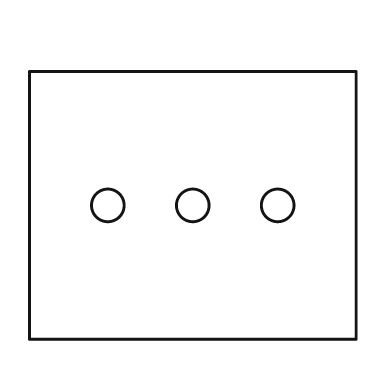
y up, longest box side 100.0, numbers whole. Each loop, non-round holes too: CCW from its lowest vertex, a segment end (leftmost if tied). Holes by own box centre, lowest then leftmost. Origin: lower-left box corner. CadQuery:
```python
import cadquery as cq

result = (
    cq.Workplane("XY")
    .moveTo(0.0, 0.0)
    .lineTo(100.0, 0.0)
    .lineTo(100.0, 82.0)
    .lineTo(0.0, 82.0)
    .close()
    .moveTo(24.0, 41.0)
    .circle(5.0)
    .moveTo(50.0, 41.0)
    .circle(5.0)
    .moveTo(76.0, 41.0)
    .circle(5.0)
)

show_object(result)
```